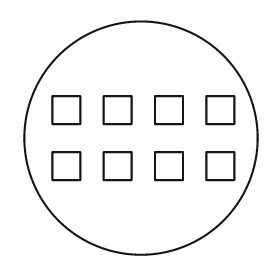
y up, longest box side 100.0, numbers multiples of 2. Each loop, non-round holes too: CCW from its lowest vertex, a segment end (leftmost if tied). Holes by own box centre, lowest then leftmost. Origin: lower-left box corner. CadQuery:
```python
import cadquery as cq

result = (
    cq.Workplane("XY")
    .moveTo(50.0, 50.0)
    .circle(50.0)
    .moveTo(12.0, 32.0)
    .lineTo(24.0, 32.0)
    .lineTo(24.0, 44.0)
    .lineTo(12.0, 44.0)
    .close()
    .moveTo(34.0, 32.0)
    .lineTo(46.0, 32.0)
    .lineTo(46.0, 44.0)
    .lineTo(34.0, 44.0)
    .close()
    .moveTo(56.0, 32.0)
    .lineTo(68.0, 32.0)
    .lineTo(68.0, 44.0)
    .lineTo(56.0, 44.0)
    .close()
    .moveTo(78.0, 32.0)
    .lineTo(90.0, 32.0)
    .lineTo(90.0, 44.0)
    .lineTo(78.0, 44.0)
    .close()
    .moveTo(12.0, 56.0)
    .lineTo(24.0, 56.0)
    .lineTo(24.0, 68.0)
    .lineTo(12.0, 68.0)
    .close()
    .moveTo(34.0, 56.0)
    .lineTo(46.0, 56.0)
    .lineTo(46.0, 68.0)
    .lineTo(34.0, 68.0)
    .close()
    .moveTo(56.0, 56.0)
    .lineTo(68.0, 56.0)
    .lineTo(68.0, 68.0)
    .lineTo(56.0, 68.0)
    .close()
    .moveTo(78.0, 56.0)
    .lineTo(90.0, 56.0)
    .lineTo(90.0, 68.0)
    .lineTo(78.0, 68.0)
    .close()
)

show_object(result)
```